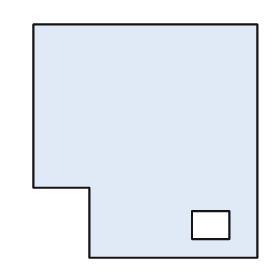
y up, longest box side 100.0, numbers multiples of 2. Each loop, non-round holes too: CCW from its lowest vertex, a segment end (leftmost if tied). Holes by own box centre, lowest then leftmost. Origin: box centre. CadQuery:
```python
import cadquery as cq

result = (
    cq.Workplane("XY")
    .moveTo(-24.0, -50.0)
    .lineTo(48.0, -50.0)
    .lineTo(48.0, 50.0)
    .lineTo(-48.0, 50.0)
    .lineTo(-48.0, -20.0)
    .lineTo(-24.0, -20.0)
    .close()
    .moveTo(20.0, -42.0)
    .lineTo(36.0, -42.0)
    .lineTo(36.0, -30.0)
    .lineTo(20.0, -30.0)
    .close()
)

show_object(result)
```